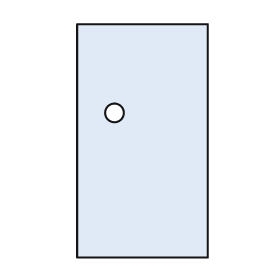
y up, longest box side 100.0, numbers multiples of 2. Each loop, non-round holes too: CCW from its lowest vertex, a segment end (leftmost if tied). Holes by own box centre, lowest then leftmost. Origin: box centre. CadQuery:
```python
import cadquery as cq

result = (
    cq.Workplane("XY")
    .moveTo(-28.0, -50.0)
    .lineTo(28.0, -50.0)
    .lineTo(28.0, 50.0)
    .lineTo(-28.0, 50.0)
    .close()
    .moveTo(-12.0, 12.0)
    .circle(4.0)
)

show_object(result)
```